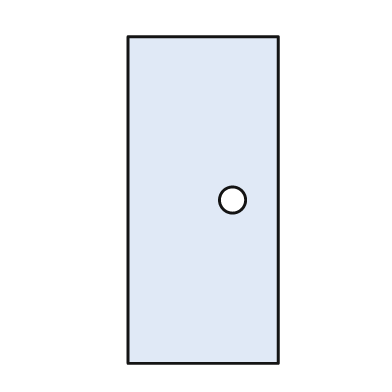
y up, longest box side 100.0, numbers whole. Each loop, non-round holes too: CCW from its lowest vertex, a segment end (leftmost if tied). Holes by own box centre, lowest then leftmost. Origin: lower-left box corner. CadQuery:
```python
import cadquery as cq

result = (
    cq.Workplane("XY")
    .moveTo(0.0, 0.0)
    .lineTo(46.0, 0.0)
    .lineTo(46.0, 100.0)
    .lineTo(0.0, 100.0)
    .close()
    .moveTo(32.0, 50.0)
    .circle(4.0)
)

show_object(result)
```